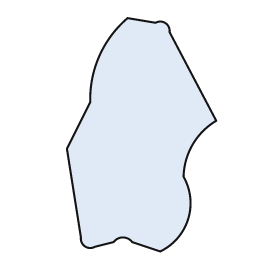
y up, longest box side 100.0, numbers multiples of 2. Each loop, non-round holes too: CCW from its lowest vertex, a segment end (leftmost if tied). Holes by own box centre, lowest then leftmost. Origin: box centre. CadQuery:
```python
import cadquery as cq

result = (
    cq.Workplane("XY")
    .moveTo(8.0, -50.0)
    .threePointArc((20.0, -36.0), (18.0, -18.0))
    .threePointArc((22.0, -4.0), (32.0, 6.0))
    .lineTo(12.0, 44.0)
    .threePointArc((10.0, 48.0), (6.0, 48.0))
    .lineTo(-6.0, 50.0)
    .threePointArc((-18.0, 34.0), (-22.0, 14.0))
    .lineTo(-32.0, -6.0)
    .lineTo(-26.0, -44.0)
    .threePointArc((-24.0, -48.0), (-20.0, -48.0))
    .lineTo(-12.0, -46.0)
    .threePointArc((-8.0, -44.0), (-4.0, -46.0))
    .close()
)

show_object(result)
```